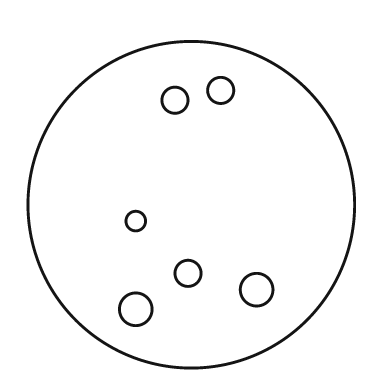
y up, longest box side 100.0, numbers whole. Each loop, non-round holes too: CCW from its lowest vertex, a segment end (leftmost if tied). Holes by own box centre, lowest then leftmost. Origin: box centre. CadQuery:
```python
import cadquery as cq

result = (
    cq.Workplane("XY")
    .moveTo(0.0, 0.0)
    .circle(50.0)
    .moveTo(-17.0, -32.0)
    .circle(5.0)
    .moveTo(20.0, -26.0)
    .circle(5.0)
    .moveTo(-1.0, -21.0)
    .circle(4.0)
    .moveTo(-17.0, -5.0)
    .circle(3.0)
    .moveTo(-5.0, 32.0)
    .circle(4.0)
    .moveTo(9.0, 35.0)
    .circle(4.0)
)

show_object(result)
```